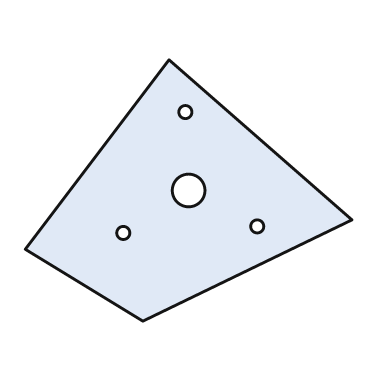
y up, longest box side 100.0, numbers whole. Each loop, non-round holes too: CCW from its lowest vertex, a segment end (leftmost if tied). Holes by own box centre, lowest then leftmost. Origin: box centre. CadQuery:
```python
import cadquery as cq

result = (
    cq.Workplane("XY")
    .moveTo(-14.0, -40.0)
    .lineTo(50.0, -9.0)
    .lineTo(-6.0, 40.0)
    .lineTo(-50.0, -18.0)
    .close()
    .moveTo(-20.0, -13.0)
    .circle(2.0)
    .moveTo(21.0, -11.0)
    .circle(2.0)
    .moveTo(0.0, 0.0)
    .circle(5.0)
    .moveTo(-1.0, 24.0)
    .circle(2.0)
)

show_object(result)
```